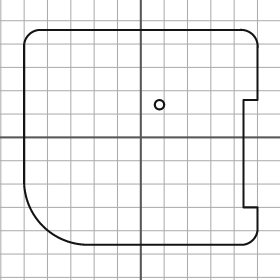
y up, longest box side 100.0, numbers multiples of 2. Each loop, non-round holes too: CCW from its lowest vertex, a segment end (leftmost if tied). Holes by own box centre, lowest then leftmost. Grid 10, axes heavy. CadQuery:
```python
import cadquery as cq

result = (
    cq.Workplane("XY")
    .moveTo(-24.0, -46.0)
    .lineTo(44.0, -46.0)
    .threePointArc((48.0, -44.0), (50.0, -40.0))
    .lineTo(50.0, -30.0)
    .lineTo(44.0, -30.0)
    .lineTo(44.0, 16.0)
    .lineTo(50.0, 16.0)
    .lineTo(50.0, 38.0)
    .threePointArc((48.0, 44.0), (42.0, 46.0))
    .lineTo(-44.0, 46.0)
    .threePointArc((-48.0, 44.0), (-50.0, 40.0))
    .lineTo(-50.0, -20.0)
    .threePointArc((-42.0, -38.0), (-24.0, -46.0))
    .close()
    .moveTo(8.0, 14.0)
    .circle(2.0)
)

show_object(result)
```